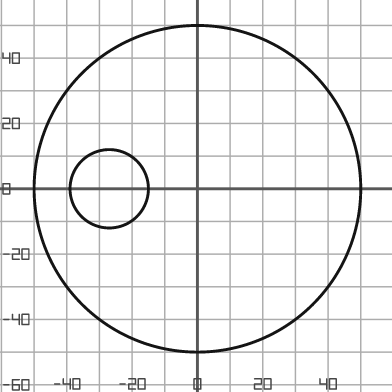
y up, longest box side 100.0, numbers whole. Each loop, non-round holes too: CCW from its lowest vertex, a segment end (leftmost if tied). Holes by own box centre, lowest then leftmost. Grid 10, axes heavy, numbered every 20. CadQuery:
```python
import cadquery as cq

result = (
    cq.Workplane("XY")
    .moveTo(0.0, 0.0)
    .circle(50.0)
    .moveTo(-27.0, 0.0)
    .circle(12.0)
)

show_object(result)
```